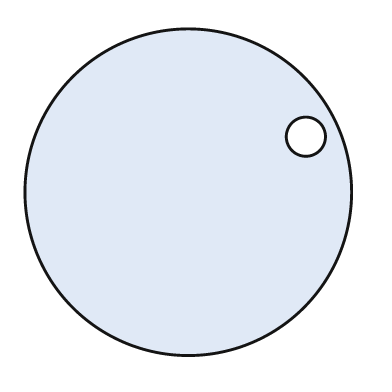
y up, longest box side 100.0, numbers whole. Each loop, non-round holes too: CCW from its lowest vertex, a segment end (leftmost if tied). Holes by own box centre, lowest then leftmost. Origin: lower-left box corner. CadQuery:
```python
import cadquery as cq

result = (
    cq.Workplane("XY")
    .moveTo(50.0, 50.0)
    .circle(50.0)
    .moveTo(86.0, 67.0)
    .circle(6.0)
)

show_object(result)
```